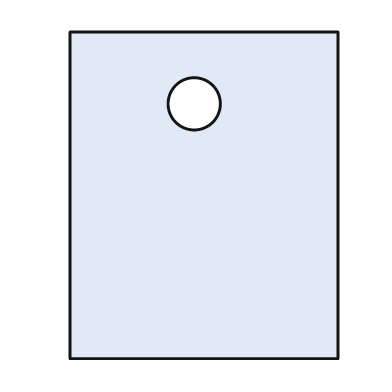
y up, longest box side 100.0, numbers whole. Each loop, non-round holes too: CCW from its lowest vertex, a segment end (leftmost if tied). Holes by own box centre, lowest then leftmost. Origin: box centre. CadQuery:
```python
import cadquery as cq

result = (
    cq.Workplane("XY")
    .moveTo(-41.0, -50.0)
    .lineTo(41.0, -50.0)
    .lineTo(41.0, 50.0)
    .lineTo(-41.0, 50.0)
    .close()
    .moveTo(-3.0, 28.0)
    .circle(8.0)
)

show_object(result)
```